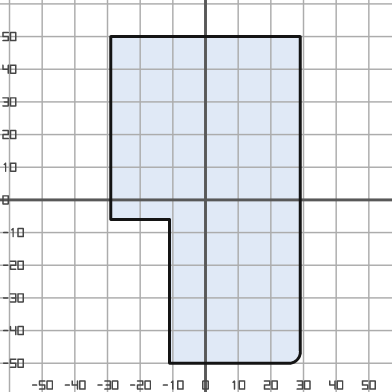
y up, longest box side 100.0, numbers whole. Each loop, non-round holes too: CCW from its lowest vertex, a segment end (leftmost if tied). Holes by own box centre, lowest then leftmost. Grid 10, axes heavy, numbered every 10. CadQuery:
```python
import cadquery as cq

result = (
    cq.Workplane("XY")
    .moveTo(-11.0, -50.0)
    .lineTo(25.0, -50.0)
    .threePointArc((28.0, -49.0), (29.0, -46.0))
    .lineTo(29.0, 50.0)
    .lineTo(-29.0, 50.0)
    .lineTo(-29.0, -6.0)
    .lineTo(-11.0, -6.0)
    .close()
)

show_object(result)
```